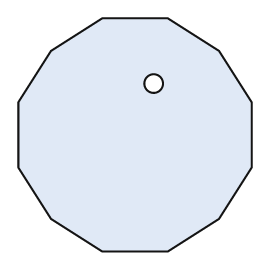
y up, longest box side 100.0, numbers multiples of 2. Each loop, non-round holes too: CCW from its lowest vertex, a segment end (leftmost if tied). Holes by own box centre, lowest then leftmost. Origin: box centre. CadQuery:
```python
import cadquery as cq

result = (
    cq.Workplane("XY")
    .moveTo(-14.0, -50.0)
    .lineTo(14.0, -50.0)
    .lineTo(36.0, -36.0)
    .lineTo(50.0, -14.0)
    .lineTo(50.0, 14.0)
    .lineTo(36.0, 36.0)
    .lineTo(14.0, 50.0)
    .lineTo(-14.0, 50.0)
    .lineTo(-36.0, 36.0)
    .lineTo(-50.0, 14.0)
    .lineTo(-50.0, -14.0)
    .lineTo(-36.0, -36.0)
    .close()
    .moveTo(8.0, 22.0)
    .circle(4.0)
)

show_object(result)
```